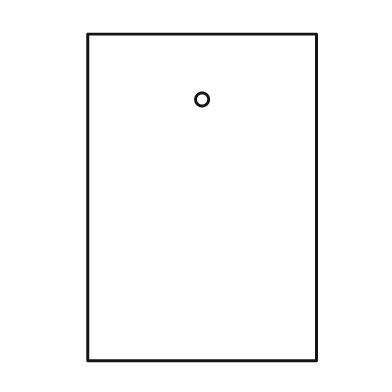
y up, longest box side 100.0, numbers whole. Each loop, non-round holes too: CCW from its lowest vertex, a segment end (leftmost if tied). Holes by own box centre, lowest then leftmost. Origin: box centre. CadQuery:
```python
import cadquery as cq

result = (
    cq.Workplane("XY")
    .moveTo(-35.0, -50.0)
    .lineTo(35.0, -50.0)
    .lineTo(35.0, 50.0)
    .lineTo(-35.0, 50.0)
    .close()
    .moveTo(0.0, 30.0)
    .circle(2.0)
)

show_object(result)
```